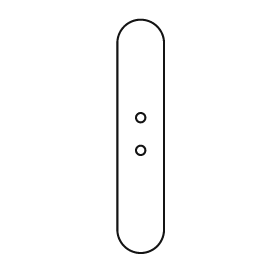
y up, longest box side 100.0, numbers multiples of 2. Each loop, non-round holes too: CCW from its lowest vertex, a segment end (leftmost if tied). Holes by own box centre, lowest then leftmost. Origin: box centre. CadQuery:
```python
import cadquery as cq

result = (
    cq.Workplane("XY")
    .moveTo(-10.0, -40.0)
    .threePointArc((0.0, -50.0), (10.0, -40.0))
    .lineTo(10.0, 40.0)
    .threePointArc((0.0, 50.0), (-10.0, 40.0))
    .close()
    .moveTo(0.0, -6.0)
    .circle(2.0)
    .moveTo(0.0, 8.0)
    .circle(2.0)
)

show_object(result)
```